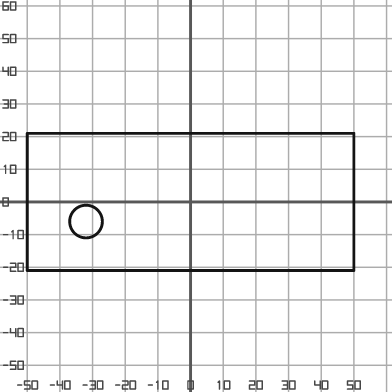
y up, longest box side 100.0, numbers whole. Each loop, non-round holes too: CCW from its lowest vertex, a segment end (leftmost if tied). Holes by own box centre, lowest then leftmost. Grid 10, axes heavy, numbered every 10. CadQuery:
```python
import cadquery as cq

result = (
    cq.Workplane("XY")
    .moveTo(-50.0, -21.0)
    .lineTo(50.0, -21.0)
    .lineTo(50.0, 21.0)
    .lineTo(-50.0, 21.0)
    .close()
    .moveTo(-32.0, -6.0)
    .circle(5.0)
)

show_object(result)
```